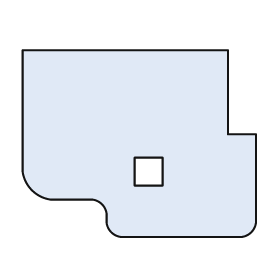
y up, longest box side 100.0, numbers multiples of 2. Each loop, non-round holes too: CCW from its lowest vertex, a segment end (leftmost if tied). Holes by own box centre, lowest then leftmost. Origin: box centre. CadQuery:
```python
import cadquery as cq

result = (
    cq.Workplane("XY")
    .moveTo(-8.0, -40.0)
    .lineTo(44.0, -40.0)
    .threePointArc((48.0, -38.0), (50.0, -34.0))
    .lineTo(50.0, 4.0)
    .lineTo(38.0, 4.0)
    .lineTo(38.0, 40.0)
    .lineTo(-50.0, 40.0)
    .lineTo(-50.0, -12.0)
    .threePointArc((-46.0, -20.0), (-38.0, -24.0))
    .lineTo(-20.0, -24.0)
    .threePointArc((-16.0, -26.0), (-14.0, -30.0))
    .lineTo(-14.0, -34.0)
    .threePointArc((-12.0, -38.0), (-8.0, -40.0))
    .close()
    .moveTo(-2.0, -18.0)
    .lineTo(10.0, -18.0)
    .lineTo(10.0, -6.0)
    .lineTo(-2.0, -6.0)
    .close()
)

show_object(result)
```